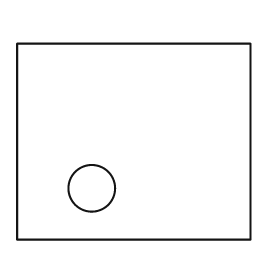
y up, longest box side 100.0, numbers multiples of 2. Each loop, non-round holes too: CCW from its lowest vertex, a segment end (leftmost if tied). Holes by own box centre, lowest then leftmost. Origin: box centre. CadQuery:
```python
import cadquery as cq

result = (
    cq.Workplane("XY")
    .moveTo(-50.0, -42.0)
    .lineTo(50.0, -42.0)
    .lineTo(50.0, 42.0)
    .lineTo(-50.0, 42.0)
    .close()
    .moveTo(-18.0, -20.0)
    .circle(10.0)
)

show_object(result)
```